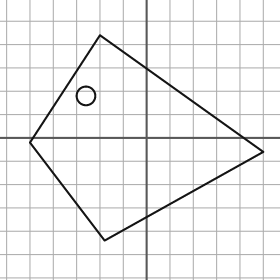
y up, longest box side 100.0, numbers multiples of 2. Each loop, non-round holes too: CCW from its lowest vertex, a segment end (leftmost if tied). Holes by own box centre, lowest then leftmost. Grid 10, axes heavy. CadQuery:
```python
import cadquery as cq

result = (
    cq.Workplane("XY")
    .moveTo(-18.0, -44.0)
    .lineTo(50.0, -6.0)
    .lineTo(-20.0, 44.0)
    .lineTo(-50.0, -2.0)
    .close()
    .moveTo(-26.0, 18.0)
    .circle(4.0)
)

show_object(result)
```